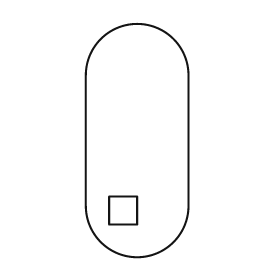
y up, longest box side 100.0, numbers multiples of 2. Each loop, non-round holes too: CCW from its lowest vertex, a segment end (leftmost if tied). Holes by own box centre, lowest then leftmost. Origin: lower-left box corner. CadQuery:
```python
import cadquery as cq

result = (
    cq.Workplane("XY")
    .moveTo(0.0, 22.0)
    .threePointArc((22.0, 0.0), (44.0, 22.0))
    .lineTo(44.0, 78.0)
    .threePointArc((22.0, 100.0), (0.0, 78.0))
    .close()
    .moveTo(10.0, 14.0)
    .lineTo(22.0, 14.0)
    .lineTo(22.0, 26.0)
    .lineTo(10.0, 26.0)
    .close()
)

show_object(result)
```